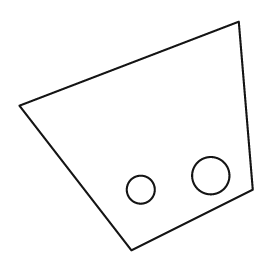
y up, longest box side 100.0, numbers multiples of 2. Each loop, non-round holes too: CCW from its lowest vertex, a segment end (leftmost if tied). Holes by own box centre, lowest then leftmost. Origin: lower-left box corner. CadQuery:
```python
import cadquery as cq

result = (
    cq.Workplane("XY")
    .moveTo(48.0, 0.0)
    .lineTo(100.0, 26.0)
    .lineTo(94.0, 98.0)
    .lineTo(0.0, 62.0)
    .close()
    .moveTo(52.0, 26.0)
    .circle(6.0)
    .moveTo(82.0, 32.0)
    .circle(8.0)
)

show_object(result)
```